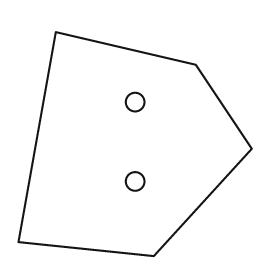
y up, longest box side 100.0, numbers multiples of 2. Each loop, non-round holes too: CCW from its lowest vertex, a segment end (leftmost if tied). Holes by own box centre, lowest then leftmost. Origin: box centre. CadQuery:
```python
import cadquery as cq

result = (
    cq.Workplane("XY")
    .moveTo(8.0, -48.0)
    .lineTo(50.0, -2.0)
    .lineTo(26.0, 34.0)
    .lineTo(-34.0, 48.0)
    .lineTo(-50.0, -42.0)
    .close()
    .moveTo(0.0, -16.0)
    .circle(4.0)
    .moveTo(0.0, 18.0)
    .circle(4.0)
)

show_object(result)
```